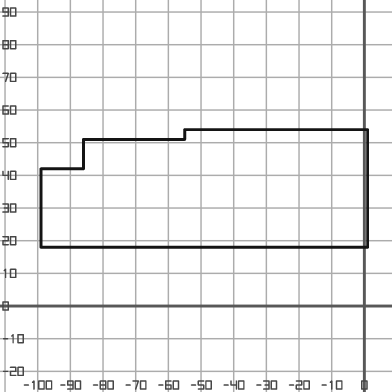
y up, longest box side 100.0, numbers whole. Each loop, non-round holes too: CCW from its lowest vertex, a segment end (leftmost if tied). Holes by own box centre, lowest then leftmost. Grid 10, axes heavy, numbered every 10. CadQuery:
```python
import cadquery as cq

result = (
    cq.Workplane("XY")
    .moveTo(-99.0, 18.0)
    .lineTo(1.0, 18.0)
    .lineTo(1.0, 54.0)
    .lineTo(-55.0, 54.0)
    .lineTo(-55.0, 51.0)
    .lineTo(-86.0, 51.0)
    .lineTo(-86.0, 42.0)
    .lineTo(-99.0, 42.0)
    .close()
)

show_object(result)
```